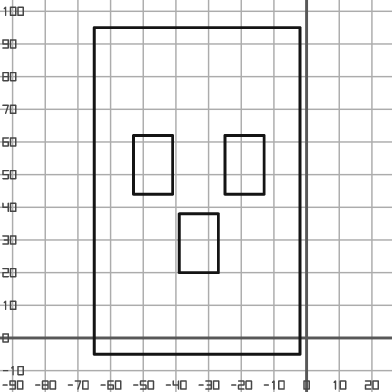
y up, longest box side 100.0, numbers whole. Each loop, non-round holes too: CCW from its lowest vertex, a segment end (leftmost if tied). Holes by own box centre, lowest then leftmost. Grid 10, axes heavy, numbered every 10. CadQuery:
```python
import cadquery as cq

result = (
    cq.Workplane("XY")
    .moveTo(-65.0, -5.0)
    .lineTo(-2.0, -5.0)
    .lineTo(-2.0, 95.0)
    .lineTo(-65.0, 95.0)
    .close()
    .moveTo(-39.0, 20.0)
    .lineTo(-27.0, 20.0)
    .lineTo(-27.0, 38.0)
    .lineTo(-39.0, 38.0)
    .close()
    .moveTo(-53.0, 44.0)
    .lineTo(-41.0, 44.0)
    .lineTo(-41.0, 62.0)
    .lineTo(-53.0, 62.0)
    .close()
    .moveTo(-25.0, 44.0)
    .lineTo(-13.0, 44.0)
    .lineTo(-13.0, 62.0)
    .lineTo(-25.0, 62.0)
    .close()
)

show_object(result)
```